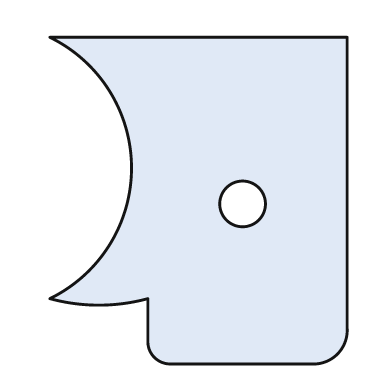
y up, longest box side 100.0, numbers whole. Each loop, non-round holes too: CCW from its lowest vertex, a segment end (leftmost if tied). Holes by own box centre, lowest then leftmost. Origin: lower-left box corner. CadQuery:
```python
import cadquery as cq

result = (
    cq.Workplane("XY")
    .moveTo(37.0, 0.0)
    .lineTo(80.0, 0.0)
    .threePointArc((88.0, 3.0), (91.0, 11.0))
    .lineTo(91.0, 100.0)
    .lineTo(0.0, 100.0)
    .threePointArc((25.0, 60.0), (0.0, 20.0))
    .threePointArc((15.0, 18.0), (30.0, 20.0))
    .lineTo(30.0, 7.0)
    .threePointArc((32.0, 2.0), (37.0, 0.0))
    .close()
    .moveTo(59.0, 49.0)
    .circle(7.0)
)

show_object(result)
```